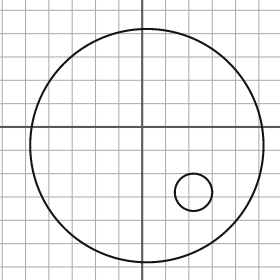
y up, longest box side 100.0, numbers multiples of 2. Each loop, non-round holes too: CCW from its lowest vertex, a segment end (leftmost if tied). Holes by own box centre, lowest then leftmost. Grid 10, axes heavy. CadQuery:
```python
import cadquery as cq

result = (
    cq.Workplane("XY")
    .moveTo(2.0, -8.0)
    .circle(50.0)
    .moveTo(22.0, -28.0)
    .circle(8.0)
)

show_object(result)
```